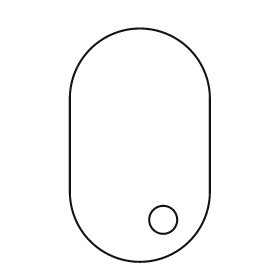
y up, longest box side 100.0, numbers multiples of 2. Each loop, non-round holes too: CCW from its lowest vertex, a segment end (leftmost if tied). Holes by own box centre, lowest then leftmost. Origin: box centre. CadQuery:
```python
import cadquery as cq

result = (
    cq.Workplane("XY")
    .moveTo(-30.0, -20.0)
    .threePointArc((0.0, -50.0), (30.0, -20.0))
    .lineTo(30.0, 20.0)
    .threePointArc((0.0, 50.0), (-30.0, 20.0))
    .close()
    .moveTo(10.0, -32.0)
    .circle(6.0)
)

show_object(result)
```